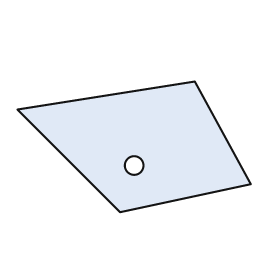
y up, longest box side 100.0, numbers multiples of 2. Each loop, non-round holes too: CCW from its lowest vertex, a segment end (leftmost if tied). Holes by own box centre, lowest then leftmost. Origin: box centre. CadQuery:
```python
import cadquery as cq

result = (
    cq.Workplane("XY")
    .moveTo(-6.0, -28.0)
    .lineTo(50.0, -16.0)
    .lineTo(26.0, 28.0)
    .lineTo(-50.0, 16.0)
    .close()
    .moveTo(0.0, -8.0)
    .circle(4.0)
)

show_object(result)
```